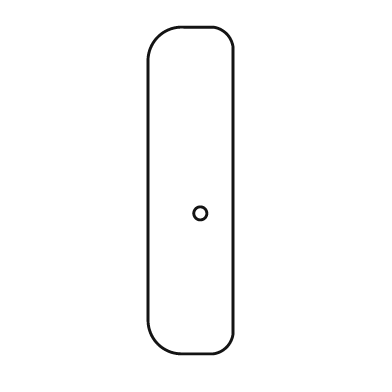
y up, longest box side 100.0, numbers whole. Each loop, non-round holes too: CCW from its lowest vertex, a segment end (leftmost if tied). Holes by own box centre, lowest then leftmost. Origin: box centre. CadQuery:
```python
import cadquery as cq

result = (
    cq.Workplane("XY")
    .moveTo(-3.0, -50.0)
    .lineTo(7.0, -50.0)
    .threePointArc((11.0, -48.0), (13.0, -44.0))
    .lineTo(13.0, 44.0)
    .threePointArc((11.0, 48.0), (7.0, 50.0))
    .lineTo(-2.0, 50.0)
    .threePointArc((-10.0, 47.0), (-13.0, 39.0))
    .lineTo(-13.0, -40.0)
    .threePointArc((-10.0, -47.0), (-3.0, -50.0))
    .close()
    .moveTo(3.0, -7.0)
    .circle(2.0)
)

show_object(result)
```